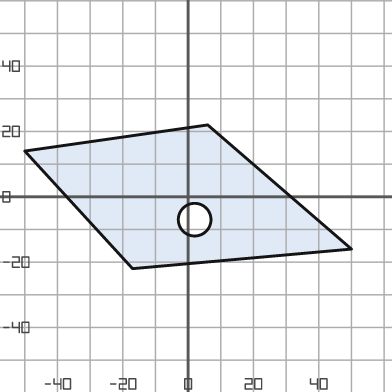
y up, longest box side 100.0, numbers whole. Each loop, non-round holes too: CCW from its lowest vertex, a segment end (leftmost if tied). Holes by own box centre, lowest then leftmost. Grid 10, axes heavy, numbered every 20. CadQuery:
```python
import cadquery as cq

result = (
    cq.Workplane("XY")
    .moveTo(-17.0, -22.0)
    .lineTo(50.0, -16.0)
    .lineTo(6.0, 22.0)
    .lineTo(-50.0, 14.0)
    .close()
    .moveTo(2.0, -7.0)
    .circle(5.0)
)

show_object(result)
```